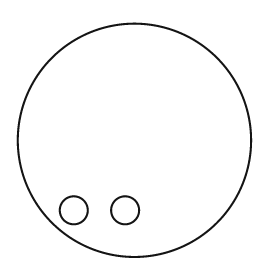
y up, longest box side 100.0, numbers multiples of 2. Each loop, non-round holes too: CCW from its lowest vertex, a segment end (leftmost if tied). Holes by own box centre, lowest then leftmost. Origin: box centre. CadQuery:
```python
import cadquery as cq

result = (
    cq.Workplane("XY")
    .moveTo(0.0, 0.0)
    .circle(50.0)
    .moveTo(-26.0, -30.0)
    .circle(6.0)
    .moveTo(-4.0, -30.0)
    .circle(6.0)
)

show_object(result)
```